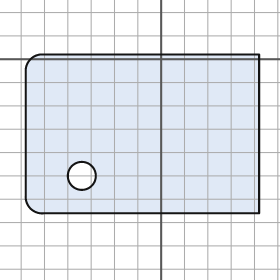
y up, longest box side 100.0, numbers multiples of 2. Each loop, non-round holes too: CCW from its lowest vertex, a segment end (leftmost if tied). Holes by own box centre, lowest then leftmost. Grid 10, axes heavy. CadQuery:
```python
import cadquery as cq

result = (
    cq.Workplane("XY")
    .moveTo(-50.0, -66.0)
    .lineTo(42.0, -66.0)
    .lineTo(42.0, 2.0)
    .lineTo(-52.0, 2.0)
    .threePointArc((-56.0, 0.0), (-58.0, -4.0))
    .lineTo(-58.0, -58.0)
    .threePointArc((-56.0, -64.0), (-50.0, -66.0))
    .close()
    .moveTo(-34.0, -50.0)
    .circle(6.0)
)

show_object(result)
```